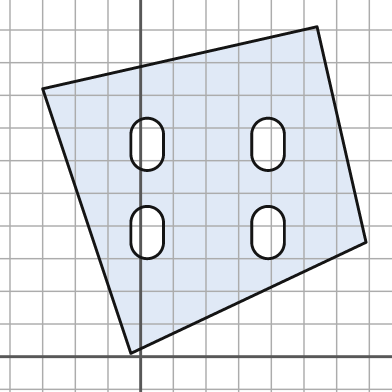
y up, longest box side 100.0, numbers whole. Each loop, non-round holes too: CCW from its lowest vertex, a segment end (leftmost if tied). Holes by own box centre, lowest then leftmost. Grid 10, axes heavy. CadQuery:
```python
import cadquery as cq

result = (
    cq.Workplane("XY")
    .moveTo(-3.0, 1.0)
    .lineTo(69.0, 35.0)
    .lineTo(54.0, 101.0)
    .lineTo(-30.0, 82.0)
    .close()
    .moveTo(-3.0, 35.0)
    .threePointArc((2.0, 30.0), (7.0, 35.0))
    .lineTo(7.0, 41.0)
    .threePointArc((2.0, 46.0), (-3.0, 41.0))
    .close()
    .moveTo(34.0, 35.0)
    .threePointArc((39.0, 30.0), (44.0, 35.0))
    .lineTo(44.0, 41.0)
    .threePointArc((39.0, 46.0), (34.0, 41.0))
    .close()
    .moveTo(-3.0, 62.0)
    .threePointArc((2.0, 57.0), (7.0, 62.0))
    .lineTo(7.0, 68.0)
    .threePointArc((2.0, 73.0), (-3.0, 68.0))
    .close()
    .moveTo(34.0, 62.0)
    .threePointArc((39.0, 57.0), (44.0, 62.0))
    .lineTo(44.0, 68.0)
    .threePointArc((39.0, 73.0), (34.0, 68.0))
    .close()
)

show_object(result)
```